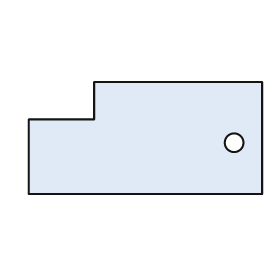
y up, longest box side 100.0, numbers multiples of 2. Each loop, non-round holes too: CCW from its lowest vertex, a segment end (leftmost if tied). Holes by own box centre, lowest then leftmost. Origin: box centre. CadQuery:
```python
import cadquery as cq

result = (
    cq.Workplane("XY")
    .moveTo(-50.0, -24.0)
    .lineTo(50.0, -24.0)
    .lineTo(50.0, 24.0)
    .lineTo(-22.0, 24.0)
    .lineTo(-22.0, 8.0)
    .lineTo(-50.0, 8.0)
    .close()
    .moveTo(38.0, -2.0)
    .circle(4.0)
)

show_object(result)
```